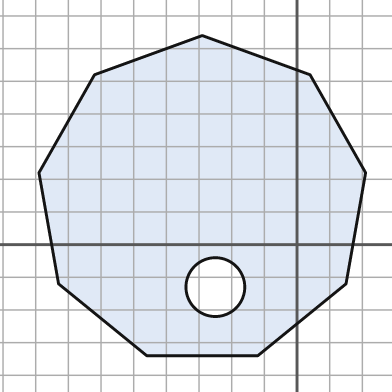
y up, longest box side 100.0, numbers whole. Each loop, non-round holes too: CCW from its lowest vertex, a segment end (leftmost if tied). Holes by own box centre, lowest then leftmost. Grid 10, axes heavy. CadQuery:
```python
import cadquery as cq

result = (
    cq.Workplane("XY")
    .moveTo(-46.0, -34.0)
    .lineTo(-12.0, -34.0)
    .lineTo(15.0, -12.0)
    .lineTo(21.0, 22.0)
    .lineTo(4.0, 52.0)
    .lineTo(-29.0, 64.0)
    .lineTo(-62.0, 52.0)
    .lineTo(-79.0, 22.0)
    .lineTo(-73.0, -12.0)
    .close()
    .moveTo(-25.0, -13.0)
    .circle(9.0)
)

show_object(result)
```